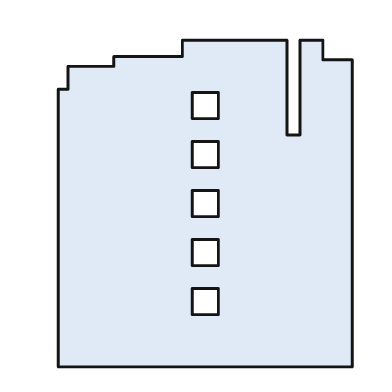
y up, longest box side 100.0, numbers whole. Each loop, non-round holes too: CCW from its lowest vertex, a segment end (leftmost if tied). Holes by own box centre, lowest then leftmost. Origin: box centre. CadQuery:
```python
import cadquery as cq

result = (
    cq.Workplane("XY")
    .moveTo(-45.0, -50.0)
    .lineTo(45.0, -50.0)
    .lineTo(45.0, 44.0)
    .lineTo(36.0, 44.0)
    .lineTo(36.0, 50.0)
    .lineTo(29.0, 50.0)
    .lineTo(29.0, 21.0)
    .lineTo(25.0, 21.0)
    .lineTo(25.0, 50.0)
    .lineTo(-7.0, 50.0)
    .lineTo(-7.0, 45.0)
    .lineTo(-28.0, 45.0)
    .lineTo(-28.0, 42.0)
    .lineTo(-42.0, 42.0)
    .lineTo(-42.0, 35.0)
    .lineTo(-45.0, 35.0)
    .close()
    .moveTo(-4.0, -34.0)
    .lineTo(4.0, -34.0)
    .lineTo(4.0, -26.0)
    .lineTo(-4.0, -26.0)
    .close()
    .moveTo(-4.0, -19.0)
    .lineTo(4.0, -19.0)
    .lineTo(4.0, -11.0)
    .lineTo(-4.0, -11.0)
    .close()
    .moveTo(-4.0, -4.0)
    .lineTo(4.0, -4.0)
    .lineTo(4.0, 4.0)
    .lineTo(-4.0, 4.0)
    .close()
    .moveTo(-4.0, 11.0)
    .lineTo(4.0, 11.0)
    .lineTo(4.0, 19.0)
    .lineTo(-4.0, 19.0)
    .close()
    .moveTo(-4.0, 26.0)
    .lineTo(4.0, 26.0)
    .lineTo(4.0, 34.0)
    .lineTo(-4.0, 34.0)
    .close()
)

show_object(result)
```